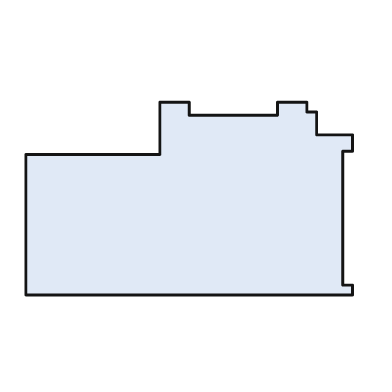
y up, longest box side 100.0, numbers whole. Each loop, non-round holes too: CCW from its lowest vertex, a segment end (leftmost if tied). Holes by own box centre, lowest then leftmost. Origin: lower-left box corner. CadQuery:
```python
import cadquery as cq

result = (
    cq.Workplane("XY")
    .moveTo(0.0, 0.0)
    .lineTo(100.0, 0.0)
    .lineTo(100.0, 3.0)
    .lineTo(97.0, 3.0)
    .lineTo(97.0, 44.0)
    .lineTo(100.0, 44.0)
    .lineTo(100.0, 49.0)
    .lineTo(89.0, 49.0)
    .lineTo(89.0, 56.0)
    .lineTo(86.0, 56.0)
    .lineTo(86.0, 59.0)
    .lineTo(77.0, 59.0)
    .lineTo(77.0, 55.0)
    .lineTo(50.0, 55.0)
    .lineTo(50.0, 59.0)
    .lineTo(41.0, 59.0)
    .lineTo(41.0, 43.0)
    .lineTo(0.0, 43.0)
    .close()
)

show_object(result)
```